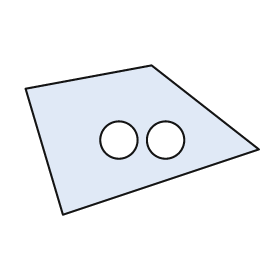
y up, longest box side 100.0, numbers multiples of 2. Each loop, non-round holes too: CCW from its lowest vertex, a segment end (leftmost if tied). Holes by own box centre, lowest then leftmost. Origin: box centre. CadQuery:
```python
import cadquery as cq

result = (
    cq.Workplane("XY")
    .moveTo(-34.0, -32.0)
    .lineTo(50.0, -4.0)
    .lineTo(4.0, 32.0)
    .lineTo(-50.0, 22.0)
    .close()
    .moveTo(-10.0, 0.0)
    .circle(8.0)
    .moveTo(10.0, 0.0)
    .circle(8.0)
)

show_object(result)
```